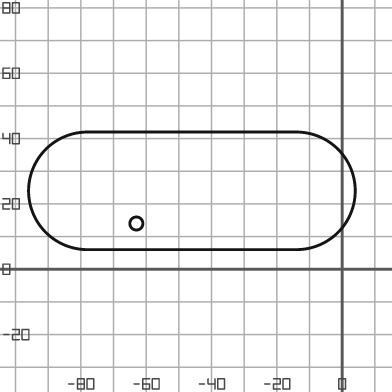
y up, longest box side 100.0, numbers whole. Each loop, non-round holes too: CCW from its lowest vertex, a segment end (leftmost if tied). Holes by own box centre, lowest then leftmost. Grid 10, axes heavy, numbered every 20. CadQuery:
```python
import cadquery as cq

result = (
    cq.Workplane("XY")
    .moveTo(-78.0, 6.0)
    .lineTo(-14.0, 6.0)
    .threePointArc((4.0, 24.0), (-14.0, 42.0))
    .lineTo(-78.0, 42.0)
    .threePointArc((-96.0, 24.0), (-78.0, 6.0))
    .close()
    .moveTo(-63.0, 14.0)
    .circle(2.0)
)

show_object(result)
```